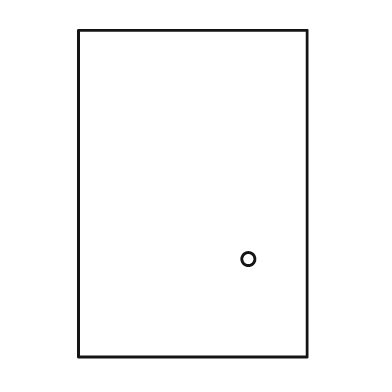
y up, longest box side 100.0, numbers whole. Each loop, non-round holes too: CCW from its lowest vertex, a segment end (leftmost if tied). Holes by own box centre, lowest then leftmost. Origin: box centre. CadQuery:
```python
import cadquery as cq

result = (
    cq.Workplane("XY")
    .moveTo(-35.0, -50.0)
    .lineTo(35.0, -50.0)
    .lineTo(35.0, 50.0)
    .lineTo(-35.0, 50.0)
    .close()
    .moveTo(17.0, -20.0)
    .circle(2.0)
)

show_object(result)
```